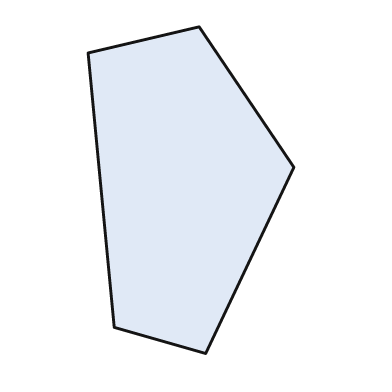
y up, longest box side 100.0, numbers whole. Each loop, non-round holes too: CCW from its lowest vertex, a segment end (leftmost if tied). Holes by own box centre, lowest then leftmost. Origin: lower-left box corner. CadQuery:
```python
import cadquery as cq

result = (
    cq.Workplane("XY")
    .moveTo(36.0, 0.0)
    .lineTo(63.0, 57.0)
    .lineTo(34.0, 100.0)
    .lineTo(0.0, 92.0)
    .lineTo(8.0, 8.0)
    .close()
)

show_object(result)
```